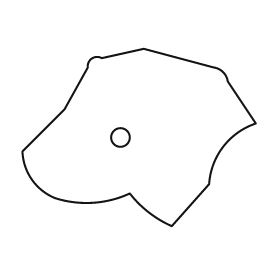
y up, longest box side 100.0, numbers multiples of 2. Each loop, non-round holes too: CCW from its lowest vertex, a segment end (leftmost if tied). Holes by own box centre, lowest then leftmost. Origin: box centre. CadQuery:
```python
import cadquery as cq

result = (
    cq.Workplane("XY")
    .moveTo(14.0, -38.0)
    .lineTo(30.0, -20.0)
    .threePointArc((36.0, -4.0), (50.0, 6.0))
    .lineTo(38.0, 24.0)
    .threePointArc((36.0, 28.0), (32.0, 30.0))
    .lineTo(2.0, 38.0)
    .lineTo(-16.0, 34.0)
    .threePointArc((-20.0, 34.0), (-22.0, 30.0))
    .lineTo(-32.0, 12.0)
    .lineTo(-50.0, -6.0)
    .threePointArc((-46.0, -18.0), (-36.0, -26.0))
    .threePointArc((-20.0, -28.0), (-4.0, -24.0))
    .threePointArc((4.0, -32.0), (14.0, -38.0))
    .close()
    .moveTo(-8.0, 0.0)
    .circle(4.0)
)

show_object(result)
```